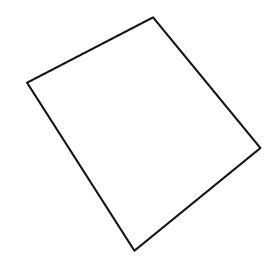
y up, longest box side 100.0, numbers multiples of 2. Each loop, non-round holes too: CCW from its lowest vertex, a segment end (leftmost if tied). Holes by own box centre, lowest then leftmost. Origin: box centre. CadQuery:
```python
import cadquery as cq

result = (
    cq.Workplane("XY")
    .moveTo(-4.0, -50.0)
    .lineTo(50.0, -6.0)
    .lineTo(4.0, 50.0)
    .lineTo(-50.0, 22.0)
    .close()
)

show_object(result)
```